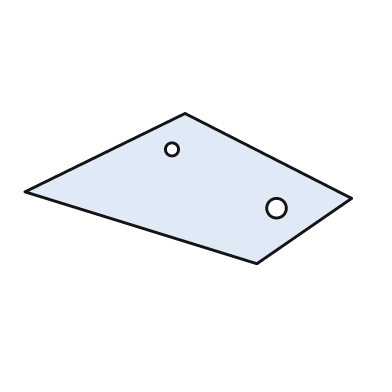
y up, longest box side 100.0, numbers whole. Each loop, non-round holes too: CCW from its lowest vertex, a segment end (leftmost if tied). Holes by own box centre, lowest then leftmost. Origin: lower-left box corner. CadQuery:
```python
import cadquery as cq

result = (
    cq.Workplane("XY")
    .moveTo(71.0, 0.0)
    .lineTo(100.0, 20.0)
    .lineTo(49.0, 46.0)
    .lineTo(0.0, 22.0)
    .close()
    .moveTo(77.0, 17.0)
    .circle(3.0)
    .moveTo(45.0, 35.0)
    .circle(2.0)
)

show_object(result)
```